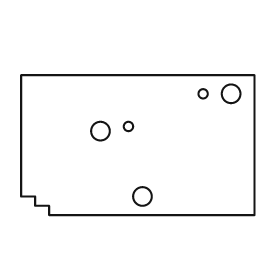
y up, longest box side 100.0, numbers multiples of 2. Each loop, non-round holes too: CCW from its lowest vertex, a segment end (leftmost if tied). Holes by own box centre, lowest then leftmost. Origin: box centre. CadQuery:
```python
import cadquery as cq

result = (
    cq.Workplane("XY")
    .moveTo(-38.0, -30.0)
    .lineTo(50.0, -30.0)
    .lineTo(50.0, 30.0)
    .lineTo(-50.0, 30.0)
    .lineTo(-50.0, -22.0)
    .lineTo(-44.0, -22.0)
    .lineTo(-44.0, -26.0)
    .lineTo(-38.0, -26.0)
    .close()
    .moveTo(2.0, -22.0)
    .circle(4.0)
    .moveTo(-16.0, 6.0)
    .circle(4.0)
    .moveTo(-4.0, 8.0)
    .circle(2.0)
    .moveTo(28.0, 22.0)
    .circle(2.0)
    .moveTo(40.0, 22.0)
    .circle(4.0)
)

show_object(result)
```